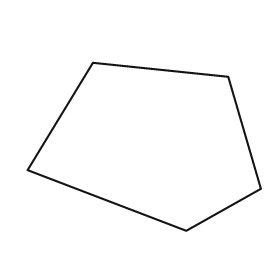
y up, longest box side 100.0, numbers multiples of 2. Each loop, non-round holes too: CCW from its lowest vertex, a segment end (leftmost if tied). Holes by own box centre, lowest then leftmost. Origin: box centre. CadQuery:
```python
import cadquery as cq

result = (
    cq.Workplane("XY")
    .moveTo(18.0, -36.0)
    .lineTo(50.0, -18.0)
    .lineTo(36.0, 30.0)
    .lineTo(-22.0, 36.0)
    .lineTo(-50.0, -10.0)
    .close()
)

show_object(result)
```